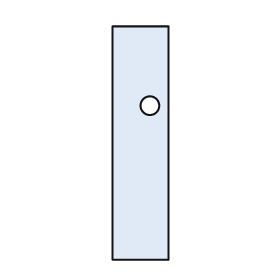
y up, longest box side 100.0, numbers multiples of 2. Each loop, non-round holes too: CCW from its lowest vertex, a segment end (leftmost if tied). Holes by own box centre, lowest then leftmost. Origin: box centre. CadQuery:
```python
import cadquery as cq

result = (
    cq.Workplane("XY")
    .moveTo(-12.0, -50.0)
    .lineTo(12.0, -50.0)
    .lineTo(12.0, 50.0)
    .lineTo(-12.0, 50.0)
    .close()
    .moveTo(4.0, 16.0)
    .circle(4.0)
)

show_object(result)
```